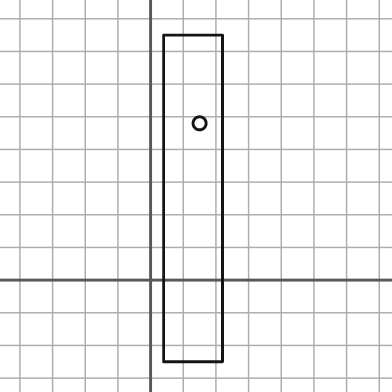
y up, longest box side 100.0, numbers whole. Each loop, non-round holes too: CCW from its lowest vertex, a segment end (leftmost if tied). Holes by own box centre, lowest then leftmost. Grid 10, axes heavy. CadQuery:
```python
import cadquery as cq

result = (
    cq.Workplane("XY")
    .moveTo(4.0, -25.0)
    .lineTo(22.0, -25.0)
    .lineTo(22.0, 75.0)
    .lineTo(4.0, 75.0)
    .close()
    .moveTo(15.0, 48.0)
    .circle(2.0)
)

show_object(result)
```